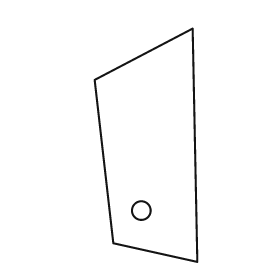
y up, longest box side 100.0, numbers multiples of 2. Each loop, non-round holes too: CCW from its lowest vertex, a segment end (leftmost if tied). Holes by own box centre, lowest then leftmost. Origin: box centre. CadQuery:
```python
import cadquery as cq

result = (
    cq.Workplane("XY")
    .moveTo(22.0, -50.0)
    .lineTo(20.0, 50.0)
    .lineTo(-22.0, 28.0)
    .lineTo(-14.0, -42.0)
    .close()
    .moveTo(-2.0, -28.0)
    .circle(4.0)
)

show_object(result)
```